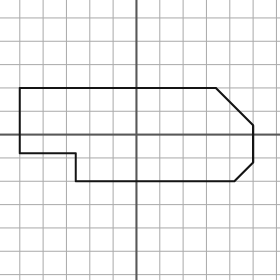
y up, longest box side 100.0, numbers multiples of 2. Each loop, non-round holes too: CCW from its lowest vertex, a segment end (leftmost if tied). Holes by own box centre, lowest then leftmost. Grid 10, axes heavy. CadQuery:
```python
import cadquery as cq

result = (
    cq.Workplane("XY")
    .moveTo(-26.0, -20.0)
    .lineTo(42.0, -20.0)
    .lineTo(50.0, -12.0)
    .lineTo(50.0, 4.0)
    .lineTo(34.0, 20.0)
    .lineTo(-50.0, 20.0)
    .lineTo(-50.0, -8.0)
    .lineTo(-26.0, -8.0)
    .close()
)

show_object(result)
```